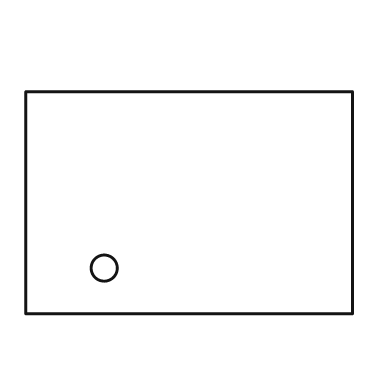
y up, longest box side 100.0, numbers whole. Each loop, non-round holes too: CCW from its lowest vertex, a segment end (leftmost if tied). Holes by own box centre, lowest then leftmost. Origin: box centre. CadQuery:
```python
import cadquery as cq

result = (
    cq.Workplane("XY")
    .moveTo(-50.0, -34.0)
    .lineTo(50.0, -34.0)
    .lineTo(50.0, 34.0)
    .lineTo(-50.0, 34.0)
    .close()
    .moveTo(-26.0, -20.0)
    .circle(4.0)
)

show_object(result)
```